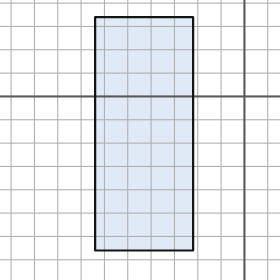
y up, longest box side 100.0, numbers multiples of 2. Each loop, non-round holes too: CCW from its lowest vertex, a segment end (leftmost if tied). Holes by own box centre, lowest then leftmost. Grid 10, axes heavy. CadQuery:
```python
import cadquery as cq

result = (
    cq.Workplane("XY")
    .moveTo(-64.0, -66.0)
    .lineTo(-22.0, -66.0)
    .lineTo(-22.0, 34.0)
    .lineTo(-64.0, 34.0)
    .close()
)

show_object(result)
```